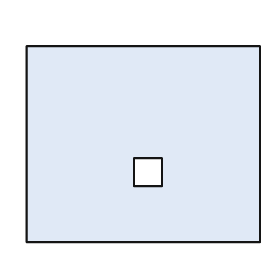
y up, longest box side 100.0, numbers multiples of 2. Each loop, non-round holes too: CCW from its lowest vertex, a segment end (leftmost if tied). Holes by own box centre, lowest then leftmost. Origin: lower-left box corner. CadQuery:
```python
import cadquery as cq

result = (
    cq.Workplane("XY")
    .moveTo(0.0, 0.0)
    .lineTo(100.0, 0.0)
    .lineTo(100.0, 84.0)
    .lineTo(0.0, 84.0)
    .close()
    .moveTo(46.0, 24.0)
    .lineTo(58.0, 24.0)
    .lineTo(58.0, 36.0)
    .lineTo(46.0, 36.0)
    .close()
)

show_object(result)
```